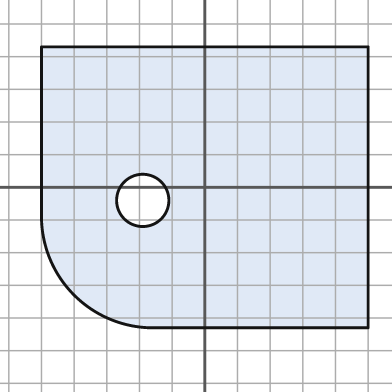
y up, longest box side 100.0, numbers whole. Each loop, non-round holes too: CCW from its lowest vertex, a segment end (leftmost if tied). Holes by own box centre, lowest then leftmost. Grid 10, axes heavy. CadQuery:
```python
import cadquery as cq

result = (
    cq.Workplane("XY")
    .moveTo(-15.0, -43.0)
    .lineTo(50.0, -43.0)
    .lineTo(50.0, 43.0)
    .lineTo(-50.0, 43.0)
    .lineTo(-50.0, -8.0)
    .threePointArc((-40.0, -33.0), (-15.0, -43.0))
    .close()
    .moveTo(-19.0, -4.0)
    .circle(8.0)
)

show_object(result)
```